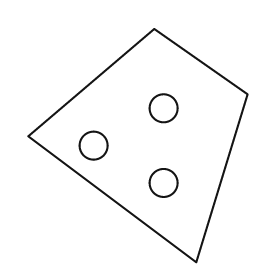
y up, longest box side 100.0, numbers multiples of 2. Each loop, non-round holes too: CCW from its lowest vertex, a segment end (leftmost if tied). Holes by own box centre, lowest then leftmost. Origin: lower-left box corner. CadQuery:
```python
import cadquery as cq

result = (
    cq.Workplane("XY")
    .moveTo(72.0, 0.0)
    .lineTo(94.0, 72.0)
    .lineTo(54.0, 100.0)
    .lineTo(0.0, 54.0)
    .close()
    .moveTo(58.0, 34.0)
    .circle(6.0)
    .moveTo(28.0, 50.0)
    .circle(6.0)
    .moveTo(58.0, 66.0)
    .circle(6.0)
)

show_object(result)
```